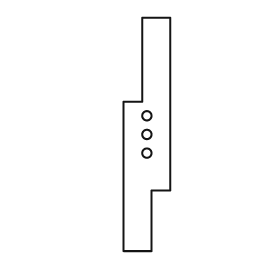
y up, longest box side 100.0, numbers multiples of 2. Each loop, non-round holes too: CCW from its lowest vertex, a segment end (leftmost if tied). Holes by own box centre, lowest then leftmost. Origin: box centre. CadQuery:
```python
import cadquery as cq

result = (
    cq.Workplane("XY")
    .moveTo(-10.0, -50.0)
    .lineTo(2.0, -50.0)
    .lineTo(2.0, -24.0)
    .lineTo(10.0, -24.0)
    .lineTo(10.0, 50.0)
    .lineTo(-2.0, 50.0)
    .lineTo(-2.0, 14.0)
    .lineTo(-10.0, 14.0)
    .close()
    .moveTo(0.0, -8.0)
    .circle(2.0)
    .moveTo(0.0, 0.0)
    .circle(2.0)
    .moveTo(0.0, 8.0)
    .circle(2.0)
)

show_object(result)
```